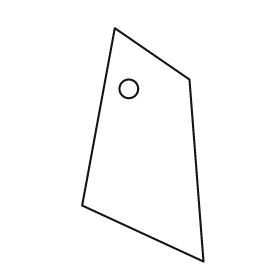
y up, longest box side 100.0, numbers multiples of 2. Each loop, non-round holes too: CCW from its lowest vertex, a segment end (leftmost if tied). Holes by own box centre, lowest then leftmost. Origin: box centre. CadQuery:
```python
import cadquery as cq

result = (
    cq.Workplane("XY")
    .moveTo(26.0, -50.0)
    .lineTo(20.0, 28.0)
    .lineTo(-12.0, 50.0)
    .lineTo(-26.0, -26.0)
    .close()
    .moveTo(-6.0, 24.0)
    .circle(4.0)
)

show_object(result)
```